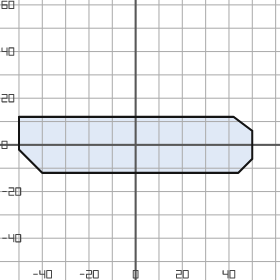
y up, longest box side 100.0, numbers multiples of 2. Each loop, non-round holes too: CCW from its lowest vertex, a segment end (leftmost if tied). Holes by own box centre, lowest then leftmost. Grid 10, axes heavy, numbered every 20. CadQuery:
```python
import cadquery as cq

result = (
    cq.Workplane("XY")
    .moveTo(-40.0, -12.0)
    .lineTo(44.0, -12.0)
    .lineTo(50.0, -6.0)
    .lineTo(50.0, 6.0)
    .lineTo(42.0, 12.0)
    .lineTo(-50.0, 12.0)
    .lineTo(-50.0, -2.0)
    .close()
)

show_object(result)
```